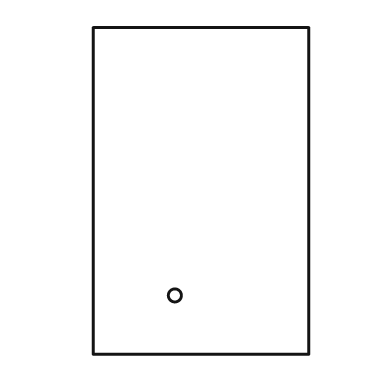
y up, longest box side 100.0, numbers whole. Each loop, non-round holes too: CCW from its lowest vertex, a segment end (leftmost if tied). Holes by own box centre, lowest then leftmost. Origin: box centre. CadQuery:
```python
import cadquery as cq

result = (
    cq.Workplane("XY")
    .moveTo(-33.0, -50.0)
    .lineTo(33.0, -50.0)
    .lineTo(33.0, 50.0)
    .lineTo(-33.0, 50.0)
    .close()
    .moveTo(-8.0, -32.0)
    .circle(2.0)
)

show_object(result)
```